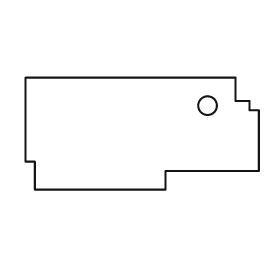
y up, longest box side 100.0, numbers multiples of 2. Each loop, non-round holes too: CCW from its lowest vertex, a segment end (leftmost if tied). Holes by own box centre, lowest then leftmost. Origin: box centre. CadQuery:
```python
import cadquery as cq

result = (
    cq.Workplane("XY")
    .moveTo(-46.0, -24.0)
    .lineTo(10.0, -24.0)
    .lineTo(10.0, -16.0)
    .lineTo(50.0, -16.0)
    .lineTo(50.0, 10.0)
    .lineTo(46.0, 10.0)
    .lineTo(46.0, 14.0)
    .lineTo(40.0, 14.0)
    .lineTo(40.0, 24.0)
    .lineTo(-50.0, 24.0)
    .lineTo(-50.0, -12.0)
    .lineTo(-46.0, -12.0)
    .close()
    .moveTo(28.0, 12.0)
    .circle(4.0)
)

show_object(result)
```